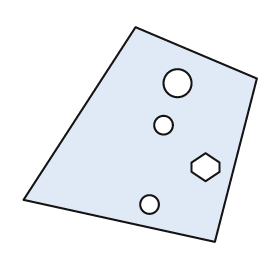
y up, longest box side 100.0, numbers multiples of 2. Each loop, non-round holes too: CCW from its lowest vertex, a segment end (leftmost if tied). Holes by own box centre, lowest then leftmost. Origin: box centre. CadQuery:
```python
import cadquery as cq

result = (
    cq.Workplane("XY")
    .moveTo(32.0, -46.0)
    .lineTo(50.0, 24.0)
    .lineTo(-2.0, 46.0)
    .lineTo(-50.0, -28.0)
    .close()
    .moveTo(4.0, -30.0)
    .circle(4.0)
    .moveTo(28.0, -20.0)
    .lineTo(34.0, -16.0)
    .lineTo(34.0, -12.0)
    .lineTo(28.0, -8.0)
    .lineTo(22.0, -12.0)
    .lineTo(22.0, -16.0)
    .close()
    .moveTo(10.0, 4.0)
    .circle(4.0)
    .moveTo(16.0, 22.0)
    .circle(6.0)
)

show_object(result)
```